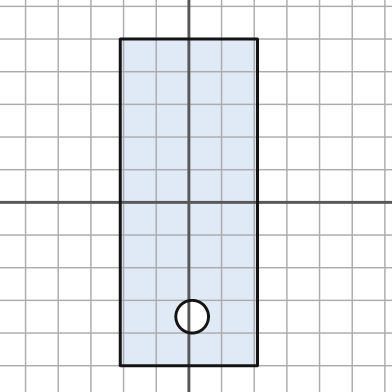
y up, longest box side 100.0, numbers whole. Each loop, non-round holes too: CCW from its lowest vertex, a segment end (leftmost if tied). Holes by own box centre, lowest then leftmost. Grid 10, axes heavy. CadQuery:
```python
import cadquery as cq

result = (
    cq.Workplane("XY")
    .moveTo(-21.0, -50.0)
    .lineTo(21.0, -50.0)
    .lineTo(21.0, 50.0)
    .lineTo(-21.0, 50.0)
    .close()
    .moveTo(1.0, -35.0)
    .circle(5.0)
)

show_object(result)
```